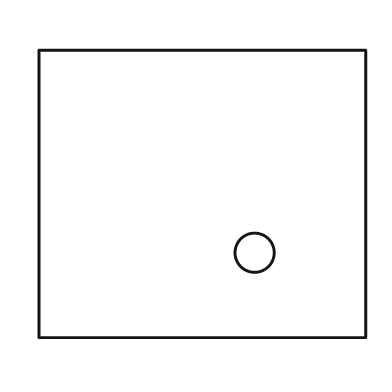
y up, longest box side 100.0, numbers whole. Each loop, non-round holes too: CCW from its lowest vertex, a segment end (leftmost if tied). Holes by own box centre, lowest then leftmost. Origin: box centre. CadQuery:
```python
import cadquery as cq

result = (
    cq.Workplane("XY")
    .moveTo(-50.0, -44.0)
    .lineTo(50.0, -44.0)
    .lineTo(50.0, 44.0)
    .lineTo(-50.0, 44.0)
    .close()
    .moveTo(16.0, -18.0)
    .circle(6.0)
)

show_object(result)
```